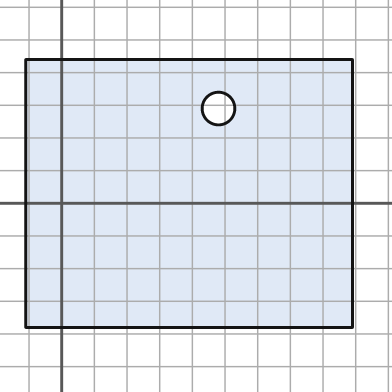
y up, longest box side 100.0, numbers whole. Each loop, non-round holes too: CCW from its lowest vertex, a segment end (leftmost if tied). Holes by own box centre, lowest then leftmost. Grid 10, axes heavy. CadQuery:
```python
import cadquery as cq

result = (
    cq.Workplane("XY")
    .moveTo(-11.0, -38.0)
    .lineTo(89.0, -38.0)
    .lineTo(89.0, 44.0)
    .lineTo(-11.0, 44.0)
    .close()
    .moveTo(48.0, 29.0)
    .circle(5.0)
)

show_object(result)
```